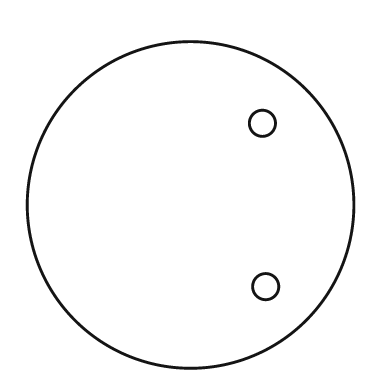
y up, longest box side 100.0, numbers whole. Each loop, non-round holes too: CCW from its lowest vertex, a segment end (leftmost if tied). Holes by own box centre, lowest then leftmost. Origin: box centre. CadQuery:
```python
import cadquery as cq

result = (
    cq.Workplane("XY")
    .moveTo(0.0, 0.0)
    .circle(50.0)
    .moveTo(23.0, -25.0)
    .circle(4.0)
    .moveTo(22.0, 25.0)
    .circle(4.0)
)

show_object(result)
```